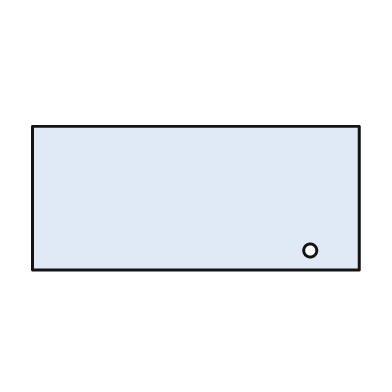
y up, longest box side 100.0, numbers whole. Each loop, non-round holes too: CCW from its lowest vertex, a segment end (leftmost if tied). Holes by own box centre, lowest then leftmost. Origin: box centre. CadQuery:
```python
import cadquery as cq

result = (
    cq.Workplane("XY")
    .moveTo(-50.0, -22.0)
    .lineTo(50.0, -22.0)
    .lineTo(50.0, 22.0)
    .lineTo(-50.0, 22.0)
    .close()
    .moveTo(35.0, -16.0)
    .circle(2.0)
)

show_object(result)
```